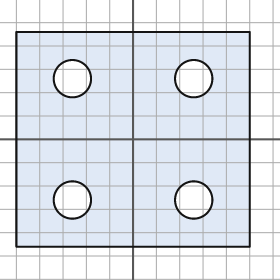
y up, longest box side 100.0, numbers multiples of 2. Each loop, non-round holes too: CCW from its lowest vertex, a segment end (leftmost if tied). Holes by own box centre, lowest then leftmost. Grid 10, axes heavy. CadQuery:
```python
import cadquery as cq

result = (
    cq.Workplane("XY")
    .moveTo(-50.0, -46.0)
    .lineTo(50.0, -46.0)
    .lineTo(50.0, 46.0)
    .lineTo(-50.0, 46.0)
    .close()
    .moveTo(-26.0, -26.0)
    .circle(8.0)
    .moveTo(26.0, -26.0)
    .circle(8.0)
    .moveTo(-26.0, 26.0)
    .circle(8.0)
    .moveTo(26.0, 26.0)
    .circle(8.0)
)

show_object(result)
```